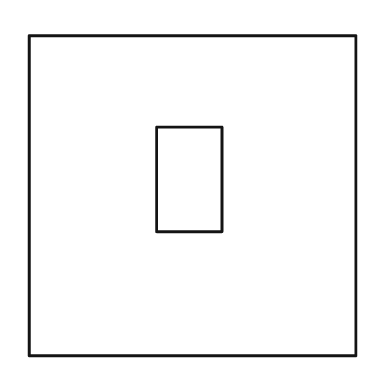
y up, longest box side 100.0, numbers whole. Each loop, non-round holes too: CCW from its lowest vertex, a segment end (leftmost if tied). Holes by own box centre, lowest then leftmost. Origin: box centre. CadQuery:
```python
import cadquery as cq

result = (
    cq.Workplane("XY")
    .moveTo(-50.0, -49.0)
    .lineTo(50.0, -49.0)
    .lineTo(50.0, 49.0)
    .lineTo(-50.0, 49.0)
    .close()
    .moveTo(-11.0, -11.0)
    .lineTo(9.0, -11.0)
    .lineTo(9.0, 21.0)
    .lineTo(-11.0, 21.0)
    .close()
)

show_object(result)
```